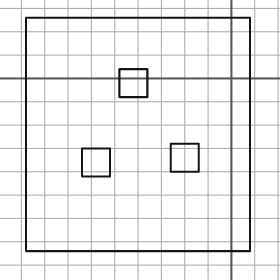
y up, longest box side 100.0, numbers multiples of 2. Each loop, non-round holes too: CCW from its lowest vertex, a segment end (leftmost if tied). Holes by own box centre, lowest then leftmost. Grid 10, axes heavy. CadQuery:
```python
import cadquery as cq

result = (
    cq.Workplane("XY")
    .moveTo(-88.0, -74.0)
    .lineTo(8.0, -74.0)
    .lineTo(8.0, 26.0)
    .lineTo(-88.0, 26.0)
    .close()
    .moveTo(-64.0, -42.0)
    .lineTo(-52.0, -42.0)
    .lineTo(-52.0, -30.0)
    .lineTo(-64.0, -30.0)
    .close()
    .moveTo(-26.0, -40.0)
    .lineTo(-14.0, -40.0)
    .lineTo(-14.0, -28.0)
    .lineTo(-26.0, -28.0)
    .close()
    .moveTo(-48.0, -8.0)
    .lineTo(-36.0, -8.0)
    .lineTo(-36.0, 4.0)
    .lineTo(-48.0, 4.0)
    .close()
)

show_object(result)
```